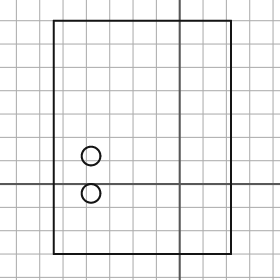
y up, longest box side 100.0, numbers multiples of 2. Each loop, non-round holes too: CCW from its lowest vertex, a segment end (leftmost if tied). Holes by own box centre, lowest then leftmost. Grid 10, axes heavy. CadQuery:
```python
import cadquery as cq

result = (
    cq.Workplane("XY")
    .moveTo(-54.0, -30.0)
    .lineTo(22.0, -30.0)
    .lineTo(22.0, 70.0)
    .lineTo(-54.0, 70.0)
    .close()
    .moveTo(-38.0, -4.0)
    .circle(4.0)
    .moveTo(-38.0, 12.0)
    .circle(4.0)
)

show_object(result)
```